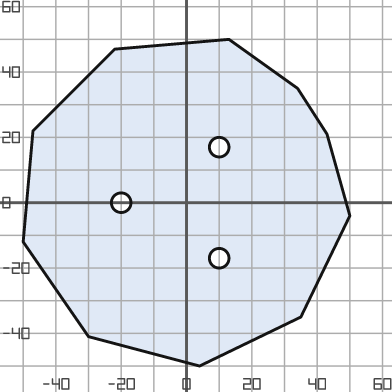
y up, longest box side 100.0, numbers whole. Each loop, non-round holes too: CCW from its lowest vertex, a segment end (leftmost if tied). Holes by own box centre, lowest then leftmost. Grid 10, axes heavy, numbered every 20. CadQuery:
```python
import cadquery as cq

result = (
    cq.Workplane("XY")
    .moveTo(4.0, -50.0)
    .lineTo(35.0, -35.0)
    .lineTo(50.0, -4.0)
    .lineTo(43.0, 21.0)
    .lineTo(34.0, 35.0)
    .lineTo(13.0, 50.0)
    .lineTo(-22.0, 47.0)
    .lineTo(-47.0, 22.0)
    .lineTo(-50.0, -12.0)
    .lineTo(-30.0, -41.0)
    .close()
    .moveTo(10.0, -17.0)
    .circle(3.0)
    .moveTo(-20.0, 0.0)
    .circle(3.0)
    .moveTo(10.0, 17.0)
    .circle(3.0)
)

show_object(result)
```